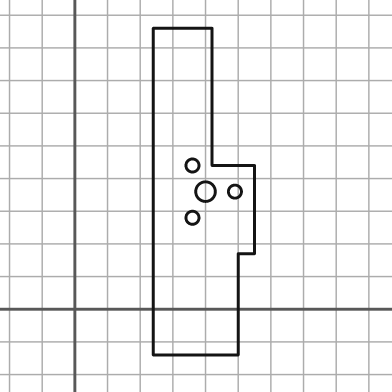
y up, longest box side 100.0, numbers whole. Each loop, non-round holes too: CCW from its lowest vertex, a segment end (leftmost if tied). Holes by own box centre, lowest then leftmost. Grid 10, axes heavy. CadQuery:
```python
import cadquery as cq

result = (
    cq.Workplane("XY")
    .moveTo(24.0, -14.0)
    .lineTo(50.0, -14.0)
    .lineTo(50.0, 17.0)
    .lineTo(55.0, 17.0)
    .lineTo(55.0, 44.0)
    .lineTo(42.0, 44.0)
    .lineTo(42.0, 86.0)
    .lineTo(24.0, 86.0)
    .close()
    .moveTo(36.0, 28.0)
    .circle(2.0)
    .moveTo(40.0, 36.0)
    .circle(3.0)
    .moveTo(49.0, 36.0)
    .circle(2.0)
    .moveTo(36.0, 44.0)
    .circle(2.0)
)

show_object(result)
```